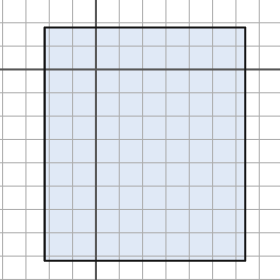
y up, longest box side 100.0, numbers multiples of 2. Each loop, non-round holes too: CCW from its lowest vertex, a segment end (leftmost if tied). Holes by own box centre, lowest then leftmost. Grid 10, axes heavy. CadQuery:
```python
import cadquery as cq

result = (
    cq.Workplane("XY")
    .moveTo(-22.0, -82.0)
    .lineTo(64.0, -82.0)
    .lineTo(64.0, 18.0)
    .lineTo(-22.0, 18.0)
    .close()
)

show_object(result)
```